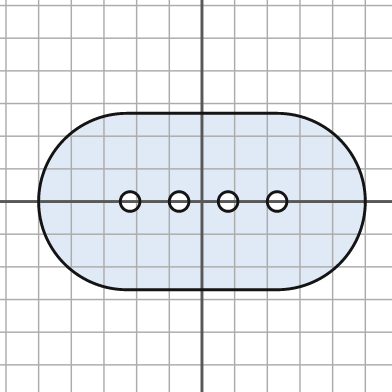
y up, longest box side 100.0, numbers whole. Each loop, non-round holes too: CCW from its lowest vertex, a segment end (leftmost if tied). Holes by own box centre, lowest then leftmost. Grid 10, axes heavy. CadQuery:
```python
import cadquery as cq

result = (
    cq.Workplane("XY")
    .moveTo(-23.0, -27.0)
    .lineTo(23.0, -27.0)
    .threePointArc((50.0, 0.0), (23.0, 27.0))
    .lineTo(-23.0, 27.0)
    .threePointArc((-50.0, 0.0), (-23.0, -27.0))
    .close()
    .moveTo(-22.0, 0.0)
    .circle(3.0)
    .moveTo(-7.0, 0.0)
    .circle(3.0)
    .moveTo(8.0, 0.0)
    .circle(3.0)
    .moveTo(23.0, 0.0)
    .circle(3.0)
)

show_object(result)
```